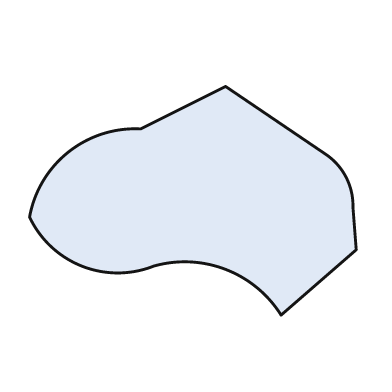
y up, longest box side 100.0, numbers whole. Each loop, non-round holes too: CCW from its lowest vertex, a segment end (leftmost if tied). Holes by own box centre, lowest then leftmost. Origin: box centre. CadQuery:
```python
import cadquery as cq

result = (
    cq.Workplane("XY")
    .moveTo(27.0, -35.0)
    .lineTo(50.0, -15.0)
    .lineTo(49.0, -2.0)
    .threePointArc((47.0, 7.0), (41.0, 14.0))
    .lineTo(10.0, 35.0)
    .lineTo(-16.0, 22.0)
    .threePointArc((-38.0, 15.0), (-50.0, -5.0))
    .threePointArc((-34.0, -20.0), (-12.0, -20.0))
    .threePointArc((10.0, -21.0), (27.0, -35.0))
    .close()
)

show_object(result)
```